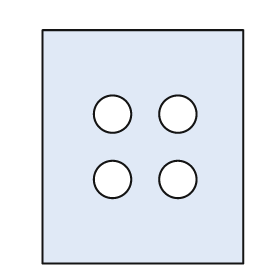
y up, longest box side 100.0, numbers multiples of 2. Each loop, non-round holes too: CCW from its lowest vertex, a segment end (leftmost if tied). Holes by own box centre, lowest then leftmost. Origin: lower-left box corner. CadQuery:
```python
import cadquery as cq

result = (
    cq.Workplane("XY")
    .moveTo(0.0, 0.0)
    .lineTo(86.0, 0.0)
    .lineTo(86.0, 100.0)
    .lineTo(0.0, 100.0)
    .close()
    .moveTo(30.0, 36.0)
    .circle(8.0)
    .moveTo(58.0, 36.0)
    .circle(8.0)
    .moveTo(30.0, 64.0)
    .circle(8.0)
    .moveTo(58.0, 64.0)
    .circle(8.0)
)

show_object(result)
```